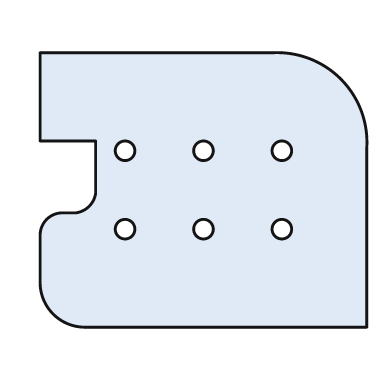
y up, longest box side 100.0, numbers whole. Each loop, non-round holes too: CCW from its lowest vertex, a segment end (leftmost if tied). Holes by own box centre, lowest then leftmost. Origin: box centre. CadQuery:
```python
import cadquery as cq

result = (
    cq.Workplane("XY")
    .moveTo(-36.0, -42.0)
    .lineTo(50.0, -42.0)
    .lineTo(50.0, 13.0)
    .threePointArc((42.0, 34.0), (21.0, 42.0))
    .lineTo(-50.0, 42.0)
    .lineTo(-50.0, 15.0)
    .lineTo(-33.0, 15.0)
    .lineTo(-33.0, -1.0)
    .threePointArc((-35.0, -5.0), (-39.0, -7.0))
    .lineTo(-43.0, -7.0)
    .threePointArc((-48.0, -9.0), (-50.0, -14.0))
    .lineTo(-50.0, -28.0)
    .threePointArc((-46.0, -38.0), (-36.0, -42.0))
    .close()
    .moveTo(-24.0, -12.0)
    .circle(3.0)
    .moveTo(0.0, -12.0)
    .circle(3.0)
    .moveTo(24.0, -12.0)
    .circle(3.0)
    .moveTo(-24.0, 12.0)
    .circle(3.0)
    .moveTo(0.0, 12.0)
    .circle(3.0)
    .moveTo(24.0, 12.0)
    .circle(3.0)
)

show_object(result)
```